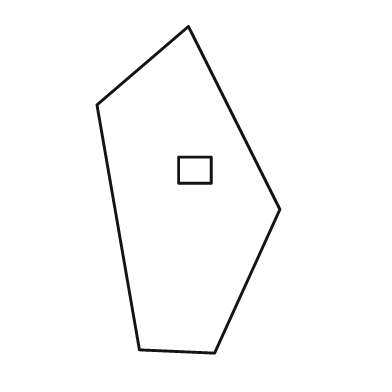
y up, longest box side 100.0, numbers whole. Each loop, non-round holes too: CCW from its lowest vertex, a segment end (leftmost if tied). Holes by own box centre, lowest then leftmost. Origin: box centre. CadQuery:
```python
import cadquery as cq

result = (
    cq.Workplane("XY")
    .moveTo(8.0, -50.0)
    .lineTo(28.0, -6.0)
    .lineTo(0.0, 50.0)
    .lineTo(-28.0, 26.0)
    .lineTo(-15.0, -49.0)
    .close()
    .moveTo(-3.0, 2.0)
    .lineTo(7.0, 2.0)
    .lineTo(7.0, 10.0)
    .lineTo(-3.0, 10.0)
    .close()
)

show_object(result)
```